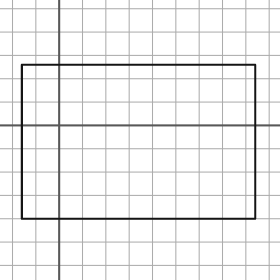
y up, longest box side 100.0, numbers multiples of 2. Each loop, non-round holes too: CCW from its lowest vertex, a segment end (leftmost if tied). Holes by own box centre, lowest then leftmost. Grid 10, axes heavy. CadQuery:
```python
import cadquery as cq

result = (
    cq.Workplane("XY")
    .moveTo(-16.0, -40.0)
    .lineTo(84.0, -40.0)
    .lineTo(84.0, 26.0)
    .lineTo(-16.0, 26.0)
    .close()
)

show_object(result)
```